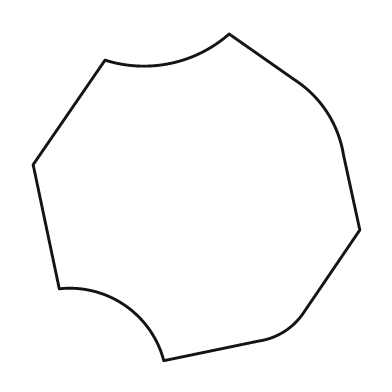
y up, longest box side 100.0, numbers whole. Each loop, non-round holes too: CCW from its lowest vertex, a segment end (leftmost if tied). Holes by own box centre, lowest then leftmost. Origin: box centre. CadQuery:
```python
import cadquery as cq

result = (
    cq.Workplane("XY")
    .moveTo(-10.0, -50.0)
    .lineTo(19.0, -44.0)
    .threePointArc((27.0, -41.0), (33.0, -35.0))
    .lineTo(50.0, -10.0)
    .lineTo(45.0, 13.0)
    .threePointArc((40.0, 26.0), (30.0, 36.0))
    .lineTo(10.0, 50.0)
    .threePointArc((-8.0, 41.0), (-28.0, 42.0))
    .lineTo(-50.0, 10.0)
    .lineTo(-42.0, -28.0)
    .threePointArc((-22.0, -33.0), (-10.0, -50.0))
    .close()
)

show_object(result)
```